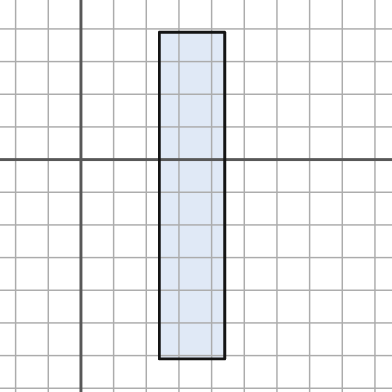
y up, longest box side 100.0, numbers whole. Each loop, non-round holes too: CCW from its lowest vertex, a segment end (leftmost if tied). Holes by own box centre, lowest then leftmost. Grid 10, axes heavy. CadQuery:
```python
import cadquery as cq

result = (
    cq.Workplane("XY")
    .moveTo(24.0, -61.0)
    .lineTo(44.0, -61.0)
    .lineTo(44.0, 39.0)
    .lineTo(24.0, 39.0)
    .close()
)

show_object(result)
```